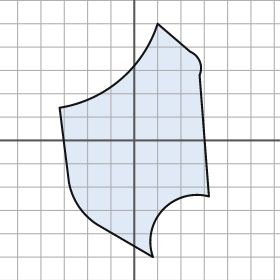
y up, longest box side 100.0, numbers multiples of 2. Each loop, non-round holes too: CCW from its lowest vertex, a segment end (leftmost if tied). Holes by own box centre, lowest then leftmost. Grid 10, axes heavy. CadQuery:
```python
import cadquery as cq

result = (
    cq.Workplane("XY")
    .moveTo(8.0, -50.0)
    .threePointArc((12.0, -30.0), (32.0, -24.0))
    .lineTo(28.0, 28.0)
    .threePointArc((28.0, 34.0), (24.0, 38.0))
    .lineTo(10.0, 50.0)
    .threePointArc((-6.0, 26.0), (-32.0, 14.0))
    .lineTo(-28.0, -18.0)
    .threePointArc((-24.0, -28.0), (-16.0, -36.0))
    .close()
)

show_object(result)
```